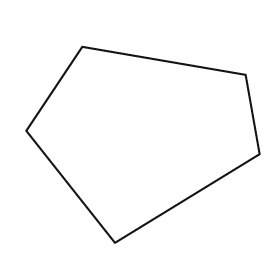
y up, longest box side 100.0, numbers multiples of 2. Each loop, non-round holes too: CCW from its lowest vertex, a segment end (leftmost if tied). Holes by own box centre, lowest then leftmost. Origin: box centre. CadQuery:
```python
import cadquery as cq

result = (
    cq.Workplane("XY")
    .moveTo(-12.0, -42.0)
    .lineTo(50.0, -4.0)
    .lineTo(44.0, 30.0)
    .lineTo(-26.0, 42.0)
    .lineTo(-50.0, 6.0)
    .close()
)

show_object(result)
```